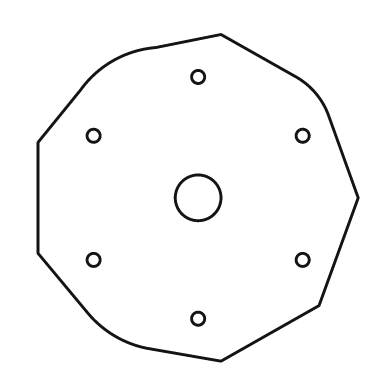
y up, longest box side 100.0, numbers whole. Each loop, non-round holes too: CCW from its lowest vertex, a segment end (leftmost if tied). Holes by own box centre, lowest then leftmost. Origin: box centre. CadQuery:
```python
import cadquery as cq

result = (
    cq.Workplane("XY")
    .moveTo(7.0, -50.0)
    .lineTo(37.0, -33.0)
    .lineTo(49.0, 0.0)
    .lineTo(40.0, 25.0)
    .threePointArc((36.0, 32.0), (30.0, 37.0))
    .lineTo(7.0, 50.0)
    .lineTo(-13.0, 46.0)
    .threePointArc((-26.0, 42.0), (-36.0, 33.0))
    .lineTo(-49.0, 17.0)
    .lineTo(-49.0, -17.0)
    .lineTo(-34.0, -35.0)
    .threePointArc((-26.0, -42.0), (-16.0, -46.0))
    .close()
    .moveTo(0.0, -37.0)
    .circle(2.0)
    .moveTo(-32.0, -19.0)
    .circle(2.0)
    .moveTo(32.0, -19.0)
    .circle(2.0)
    .moveTo(0.0, 0.0)
    .circle(7.0)
    .moveTo(-32.0, 19.0)
    .circle(2.0)
    .moveTo(32.0, 19.0)
    .circle(2.0)
    .moveTo(0.0, 37.0)
    .circle(2.0)
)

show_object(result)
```